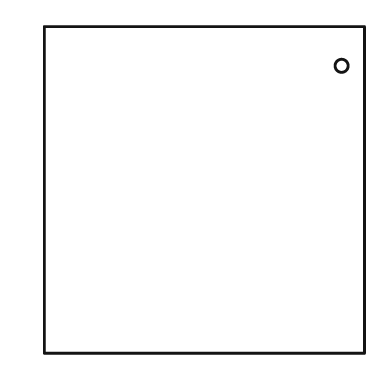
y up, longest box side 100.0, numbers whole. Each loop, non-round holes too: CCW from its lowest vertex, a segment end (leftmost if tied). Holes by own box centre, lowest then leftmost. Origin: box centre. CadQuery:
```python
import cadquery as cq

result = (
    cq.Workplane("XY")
    .moveTo(-49.0, -50.0)
    .lineTo(49.0, -50.0)
    .lineTo(49.0, 50.0)
    .lineTo(-49.0, 50.0)
    .close()
    .moveTo(42.0, 38.0)
    .circle(2.0)
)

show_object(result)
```